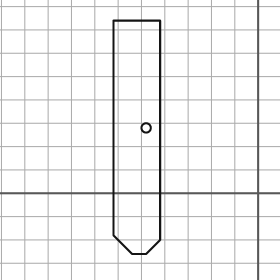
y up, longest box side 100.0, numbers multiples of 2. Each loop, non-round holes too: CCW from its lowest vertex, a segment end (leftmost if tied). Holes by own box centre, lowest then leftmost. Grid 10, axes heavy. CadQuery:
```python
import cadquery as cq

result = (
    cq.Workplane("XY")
    .moveTo(-54.0, -26.0)
    .lineTo(-48.0, -26.0)
    .lineTo(-42.0, -20.0)
    .lineTo(-42.0, 74.0)
    .lineTo(-62.0, 74.0)
    .lineTo(-62.0, -18.0)
    .close()
    .moveTo(-48.0, 28.0)
    .circle(2.0)
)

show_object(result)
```